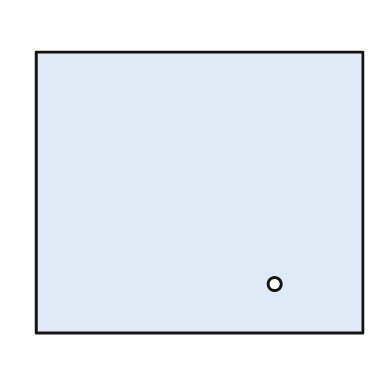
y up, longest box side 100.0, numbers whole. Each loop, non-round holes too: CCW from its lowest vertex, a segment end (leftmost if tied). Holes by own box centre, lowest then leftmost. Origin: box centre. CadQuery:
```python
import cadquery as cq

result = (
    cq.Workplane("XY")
    .moveTo(-50.0, -43.0)
    .lineTo(50.0, -43.0)
    .lineTo(50.0, 43.0)
    .lineTo(-50.0, 43.0)
    .close()
    .moveTo(23.0, -28.0)
    .circle(2.0)
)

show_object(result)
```